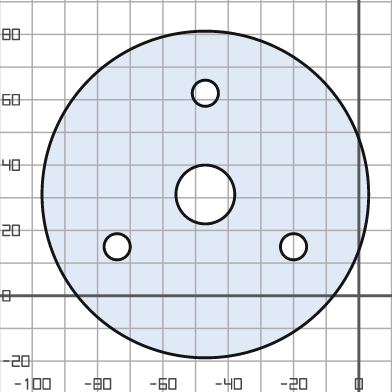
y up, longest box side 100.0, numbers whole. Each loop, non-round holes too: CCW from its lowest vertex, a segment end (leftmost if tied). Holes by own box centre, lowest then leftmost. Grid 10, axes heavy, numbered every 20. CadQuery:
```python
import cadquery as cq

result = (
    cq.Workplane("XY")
    .moveTo(-47.0, 31.0)
    .circle(50.0)
    .moveTo(-74.0, 15.0)
    .circle(4.0)
    .moveTo(-20.0, 15.0)
    .circle(4.0)
    .moveTo(-47.0, 31.0)
    .circle(9.0)
    .moveTo(-47.0, 62.0)
    .circle(4.0)
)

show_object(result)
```